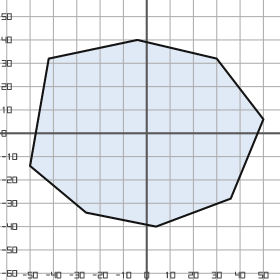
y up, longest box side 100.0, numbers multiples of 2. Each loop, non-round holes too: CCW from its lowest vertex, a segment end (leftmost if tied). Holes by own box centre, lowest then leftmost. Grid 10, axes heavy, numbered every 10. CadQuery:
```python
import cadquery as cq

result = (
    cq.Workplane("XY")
    .moveTo(4.0, -40.0)
    .lineTo(36.0, -28.0)
    .lineTo(50.0, 6.0)
    .lineTo(30.0, 32.0)
    .lineTo(-4.0, 40.0)
    .lineTo(-42.0, 32.0)
    .lineTo(-50.0, -14.0)
    .lineTo(-26.0, -34.0)
    .close()
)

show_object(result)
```